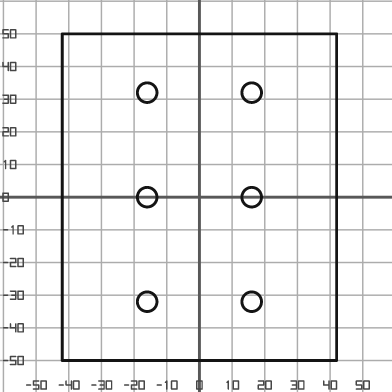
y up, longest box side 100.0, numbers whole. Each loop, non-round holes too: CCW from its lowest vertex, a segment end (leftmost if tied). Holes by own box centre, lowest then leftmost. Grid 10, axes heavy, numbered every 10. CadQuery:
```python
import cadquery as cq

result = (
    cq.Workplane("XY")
    .moveTo(-42.0, -50.0)
    .lineTo(42.0, -50.0)
    .lineTo(42.0, 50.0)
    .lineTo(-42.0, 50.0)
    .close()
    .moveTo(-16.0, -32.0)
    .circle(3.0)
    .moveTo(16.0, -32.0)
    .circle(3.0)
    .moveTo(-16.0, 0.0)
    .circle(3.0)
    .moveTo(16.0, 0.0)
    .circle(3.0)
    .moveTo(-16.0, 32.0)
    .circle(3.0)
    .moveTo(16.0, 32.0)
    .circle(3.0)
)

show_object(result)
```